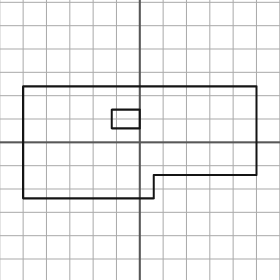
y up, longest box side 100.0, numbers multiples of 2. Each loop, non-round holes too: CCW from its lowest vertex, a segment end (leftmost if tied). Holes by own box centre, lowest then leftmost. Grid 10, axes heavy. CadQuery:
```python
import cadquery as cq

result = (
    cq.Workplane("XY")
    .moveTo(-50.0, -24.0)
    .lineTo(6.0, -24.0)
    .lineTo(6.0, -14.0)
    .lineTo(50.0, -14.0)
    .lineTo(50.0, 24.0)
    .lineTo(-50.0, 24.0)
    .close()
    .moveTo(-12.0, 6.0)
    .lineTo(0.0, 6.0)
    .lineTo(0.0, 14.0)
    .lineTo(-12.0, 14.0)
    .close()
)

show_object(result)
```